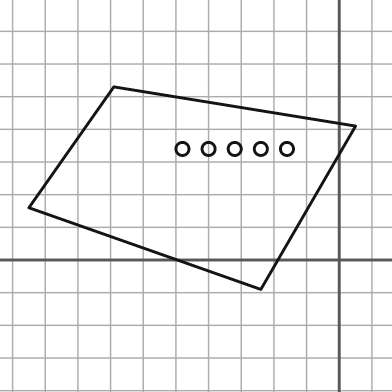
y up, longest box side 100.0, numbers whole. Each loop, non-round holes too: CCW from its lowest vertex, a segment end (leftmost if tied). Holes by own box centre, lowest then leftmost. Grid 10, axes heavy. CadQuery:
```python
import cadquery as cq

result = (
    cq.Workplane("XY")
    .moveTo(-24.0, -9.0)
    .lineTo(5.0, 41.0)
    .lineTo(-69.0, 53.0)
    .lineTo(-95.0, 16.0)
    .close()
    .moveTo(-48.0, 34.0)
    .circle(2.0)
    .moveTo(-40.0, 34.0)
    .circle(2.0)
    .moveTo(-32.0, 34.0)
    .circle(2.0)
    .moveTo(-24.0, 34.0)
    .circle(2.0)
    .moveTo(-16.0, 34.0)
    .circle(2.0)
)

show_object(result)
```